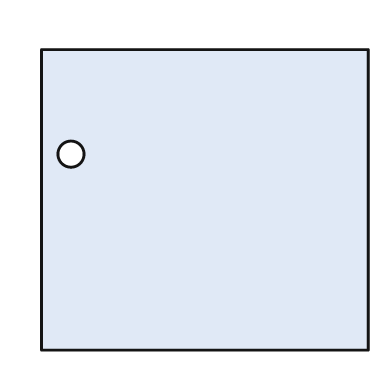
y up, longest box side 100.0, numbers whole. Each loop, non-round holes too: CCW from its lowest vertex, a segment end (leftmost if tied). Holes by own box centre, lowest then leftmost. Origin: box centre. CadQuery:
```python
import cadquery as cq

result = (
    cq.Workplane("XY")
    .moveTo(-50.0, -46.0)
    .lineTo(50.0, -46.0)
    .lineTo(50.0, 46.0)
    .lineTo(-50.0, 46.0)
    .close()
    .moveTo(-41.0, 14.0)
    .circle(4.0)
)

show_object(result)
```